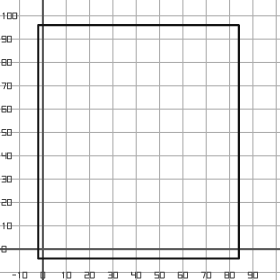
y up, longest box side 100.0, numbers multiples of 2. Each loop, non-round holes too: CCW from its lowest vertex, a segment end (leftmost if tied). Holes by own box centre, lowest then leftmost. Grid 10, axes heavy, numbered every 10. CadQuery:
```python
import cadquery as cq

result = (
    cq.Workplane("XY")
    .moveTo(-2.0, -4.0)
    .lineTo(84.0, -4.0)
    .lineTo(84.0, 96.0)
    .lineTo(-2.0, 96.0)
    .close()
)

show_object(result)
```